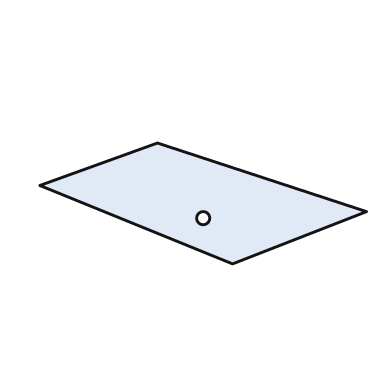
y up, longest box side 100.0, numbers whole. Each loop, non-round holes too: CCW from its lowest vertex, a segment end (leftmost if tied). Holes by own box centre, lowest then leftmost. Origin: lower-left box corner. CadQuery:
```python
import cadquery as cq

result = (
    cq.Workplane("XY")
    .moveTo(59.0, 0.0)
    .lineTo(100.0, 16.0)
    .lineTo(36.0, 37.0)
    .lineTo(0.0, 24.0)
    .close()
    .moveTo(50.0, 14.0)
    .circle(2.0)
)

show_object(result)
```